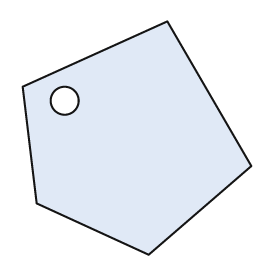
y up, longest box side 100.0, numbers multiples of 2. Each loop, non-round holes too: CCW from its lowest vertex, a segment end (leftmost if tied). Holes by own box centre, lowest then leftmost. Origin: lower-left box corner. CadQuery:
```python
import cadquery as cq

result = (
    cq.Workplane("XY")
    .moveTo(54.0, 0.0)
    .lineTo(98.0, 38.0)
    .lineTo(62.0, 100.0)
    .lineTo(0.0, 72.0)
    .lineTo(6.0, 22.0)
    .close()
    .moveTo(18.0, 66.0)
    .circle(6.0)
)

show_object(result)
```